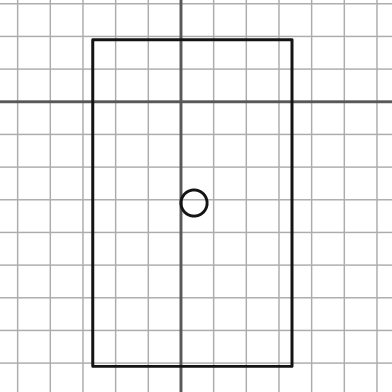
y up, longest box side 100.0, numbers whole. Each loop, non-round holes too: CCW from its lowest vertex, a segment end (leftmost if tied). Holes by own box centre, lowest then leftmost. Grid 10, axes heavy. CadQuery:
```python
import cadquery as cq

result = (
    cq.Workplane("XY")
    .moveTo(-27.0, -81.0)
    .lineTo(34.0, -81.0)
    .lineTo(34.0, 19.0)
    .lineTo(-27.0, 19.0)
    .close()
    .moveTo(4.0, -31.0)
    .circle(4.0)
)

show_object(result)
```